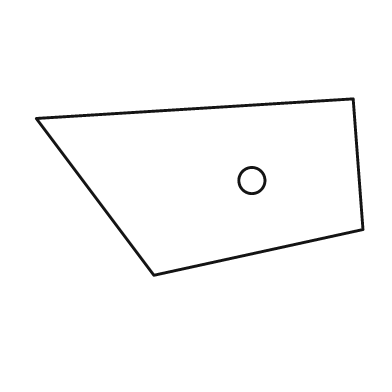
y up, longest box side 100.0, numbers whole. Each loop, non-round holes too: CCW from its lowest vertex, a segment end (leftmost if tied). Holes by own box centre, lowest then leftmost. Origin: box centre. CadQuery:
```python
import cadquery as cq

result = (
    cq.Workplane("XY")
    .moveTo(-14.0, -27.0)
    .lineTo(50.0, -13.0)
    .lineTo(47.0, 27.0)
    .lineTo(-50.0, 21.0)
    .close()
    .moveTo(16.0, 2.0)
    .circle(4.0)
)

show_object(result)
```